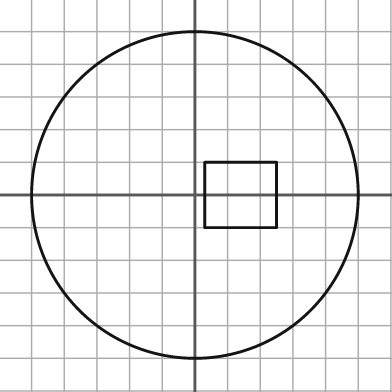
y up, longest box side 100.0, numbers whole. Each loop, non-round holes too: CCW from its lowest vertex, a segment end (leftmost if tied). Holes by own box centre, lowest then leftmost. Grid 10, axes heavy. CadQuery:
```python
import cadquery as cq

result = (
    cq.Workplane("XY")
    .moveTo(0.0, 0.0)
    .circle(50.0)
    .moveTo(3.0, -10.0)
    .lineTo(25.0, -10.0)
    .lineTo(25.0, 10.0)
    .lineTo(3.0, 10.0)
    .close()
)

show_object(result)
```